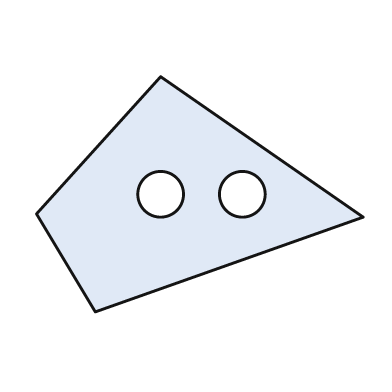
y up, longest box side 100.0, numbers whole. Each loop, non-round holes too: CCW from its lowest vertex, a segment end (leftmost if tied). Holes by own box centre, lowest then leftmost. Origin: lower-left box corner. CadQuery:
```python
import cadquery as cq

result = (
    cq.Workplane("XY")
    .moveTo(18.0, 0.0)
    .lineTo(100.0, 29.0)
    .lineTo(38.0, 72.0)
    .lineTo(0.0, 30.0)
    .close()
    .moveTo(38.0, 36.0)
    .circle(7.0)
    .moveTo(63.0, 36.0)
    .circle(7.0)
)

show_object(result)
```